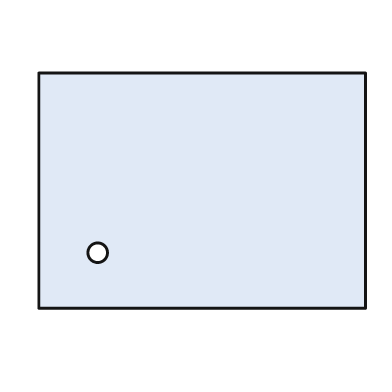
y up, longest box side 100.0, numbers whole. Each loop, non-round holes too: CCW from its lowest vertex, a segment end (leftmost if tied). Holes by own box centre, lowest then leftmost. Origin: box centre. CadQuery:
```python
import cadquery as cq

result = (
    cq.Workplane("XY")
    .moveTo(-50.0, -36.0)
    .lineTo(50.0, -36.0)
    .lineTo(50.0, 36.0)
    .lineTo(-50.0, 36.0)
    .close()
    .moveTo(-32.0, -19.0)
    .circle(3.0)
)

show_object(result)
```